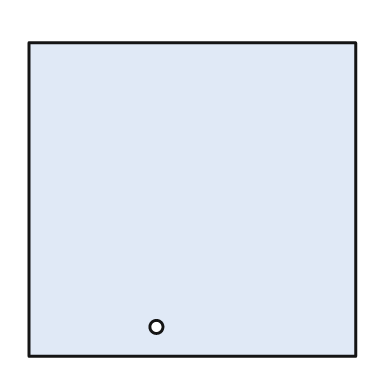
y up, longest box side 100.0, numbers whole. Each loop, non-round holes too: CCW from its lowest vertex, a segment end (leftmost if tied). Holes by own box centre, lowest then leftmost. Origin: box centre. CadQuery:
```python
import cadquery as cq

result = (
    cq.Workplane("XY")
    .moveTo(-50.0, -48.0)
    .lineTo(50.0, -48.0)
    .lineTo(50.0, 48.0)
    .lineTo(-50.0, 48.0)
    .close()
    .moveTo(-11.0, -39.0)
    .circle(2.0)
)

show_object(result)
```